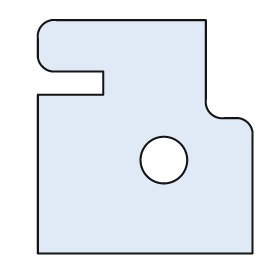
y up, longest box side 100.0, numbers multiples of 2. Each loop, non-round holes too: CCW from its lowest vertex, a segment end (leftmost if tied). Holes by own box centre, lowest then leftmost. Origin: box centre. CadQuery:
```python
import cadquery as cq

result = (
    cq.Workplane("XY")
    .moveTo(-46.0, -50.0)
    .lineTo(46.0, -50.0)
    .lineTo(46.0, 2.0)
    .threePointArc((44.0, 6.0), (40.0, 8.0))
    .lineTo(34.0, 8.0)
    .threePointArc((28.0, 10.0), (26.0, 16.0))
    .lineTo(26.0, 50.0)
    .lineTo(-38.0, 50.0)
    .threePointArc((-44.0, 48.0), (-46.0, 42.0))
    .lineTo(-46.0, 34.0)
    .threePointArc((-44.0, 30.0), (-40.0, 28.0))
    .lineTo(-18.0, 28.0)
    .lineTo(-18.0, 18.0)
    .lineTo(-46.0, 18.0)
    .close()
    .moveTo(8.0, -10.0)
    .circle(10.0)
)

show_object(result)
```